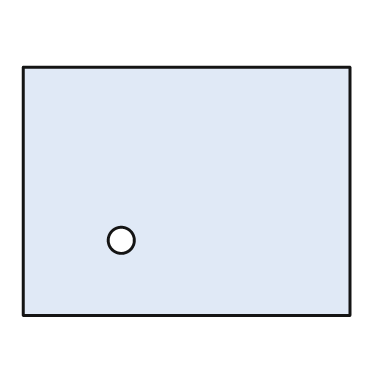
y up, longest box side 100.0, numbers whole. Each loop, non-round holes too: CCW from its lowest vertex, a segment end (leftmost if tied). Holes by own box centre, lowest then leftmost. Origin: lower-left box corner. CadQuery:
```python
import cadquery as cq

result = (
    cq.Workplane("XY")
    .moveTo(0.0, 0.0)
    .lineTo(100.0, 0.0)
    .lineTo(100.0, 76.0)
    .lineTo(0.0, 76.0)
    .close()
    .moveTo(30.0, 23.0)
    .circle(4.0)
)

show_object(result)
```